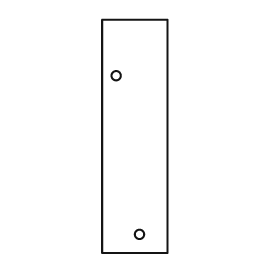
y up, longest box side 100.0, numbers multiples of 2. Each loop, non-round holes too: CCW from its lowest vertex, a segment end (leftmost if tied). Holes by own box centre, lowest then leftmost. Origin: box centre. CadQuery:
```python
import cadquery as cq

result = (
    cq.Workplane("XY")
    .moveTo(-14.0, -50.0)
    .lineTo(14.0, -50.0)
    .lineTo(14.0, 50.0)
    .lineTo(-14.0, 50.0)
    .close()
    .moveTo(2.0, -42.0)
    .circle(2.0)
    .moveTo(-8.0, 26.0)
    .circle(2.0)
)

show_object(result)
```